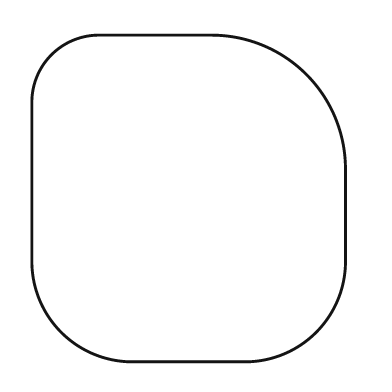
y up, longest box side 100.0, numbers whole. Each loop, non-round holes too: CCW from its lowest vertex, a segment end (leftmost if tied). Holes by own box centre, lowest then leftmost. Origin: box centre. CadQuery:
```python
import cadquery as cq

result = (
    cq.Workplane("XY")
    .moveTo(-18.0, -50.0)
    .lineTo(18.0, -50.0)
    .threePointArc((39.0, -41.0), (48.0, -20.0))
    .lineTo(48.0, 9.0)
    .threePointArc((36.0, 38.0), (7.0, 50.0))
    .lineTo(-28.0, 50.0)
    .threePointArc((-42.0, 44.0), (-48.0, 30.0))
    .lineTo(-48.0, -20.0)
    .threePointArc((-39.0, -41.0), (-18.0, -50.0))
    .close()
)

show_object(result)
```